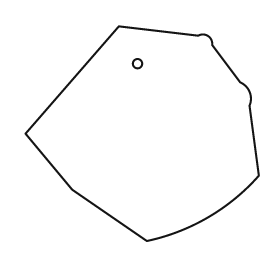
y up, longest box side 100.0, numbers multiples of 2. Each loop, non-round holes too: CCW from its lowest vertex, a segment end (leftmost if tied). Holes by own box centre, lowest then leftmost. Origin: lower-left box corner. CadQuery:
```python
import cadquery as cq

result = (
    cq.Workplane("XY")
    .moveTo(52.0, 0.0)
    .threePointArc((78.0, 10.0), (100.0, 28.0))
    .lineTo(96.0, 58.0)
    .threePointArc((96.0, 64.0), (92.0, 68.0))
    .lineTo(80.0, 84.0)
    .threePointArc((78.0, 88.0), (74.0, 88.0))
    .lineTo(40.0, 92.0)
    .lineTo(0.0, 46.0)
    .lineTo(20.0, 22.0)
    .close()
    .moveTo(48.0, 76.0)
    .circle(2.0)
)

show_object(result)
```